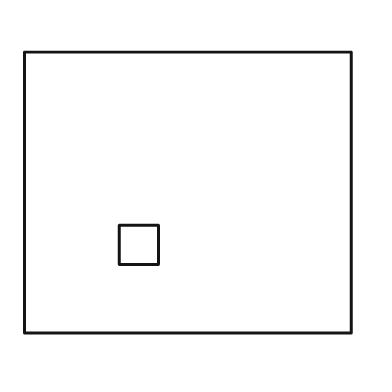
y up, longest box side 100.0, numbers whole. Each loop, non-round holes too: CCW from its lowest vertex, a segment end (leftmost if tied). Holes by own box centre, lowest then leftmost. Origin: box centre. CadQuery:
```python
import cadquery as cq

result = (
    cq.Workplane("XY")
    .moveTo(-50.0, -43.0)
    .lineTo(50.0, -43.0)
    .lineTo(50.0, 43.0)
    .lineTo(-50.0, 43.0)
    .close()
    .moveTo(-21.0, -22.0)
    .lineTo(-9.0, -22.0)
    .lineTo(-9.0, -10.0)
    .lineTo(-21.0, -10.0)
    .close()
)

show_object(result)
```